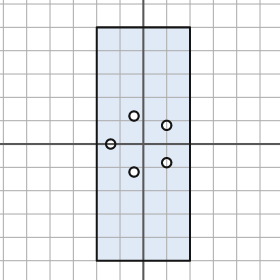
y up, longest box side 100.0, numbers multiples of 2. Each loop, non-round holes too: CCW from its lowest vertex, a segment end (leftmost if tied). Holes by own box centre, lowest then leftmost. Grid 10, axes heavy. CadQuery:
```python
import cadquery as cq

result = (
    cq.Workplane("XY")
    .moveTo(-20.0, -50.0)
    .lineTo(20.0, -50.0)
    .lineTo(20.0, 50.0)
    .lineTo(-20.0, 50.0)
    .close()
    .moveTo(-4.0, -12.0)
    .circle(2.0)
    .moveTo(10.0, -8.0)
    .circle(2.0)
    .moveTo(-14.0, 0.0)
    .circle(2.0)
    .moveTo(10.0, 8.0)
    .circle(2.0)
    .moveTo(-4.0, 12.0)
    .circle(2.0)
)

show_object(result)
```